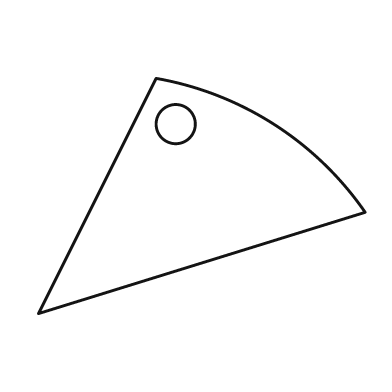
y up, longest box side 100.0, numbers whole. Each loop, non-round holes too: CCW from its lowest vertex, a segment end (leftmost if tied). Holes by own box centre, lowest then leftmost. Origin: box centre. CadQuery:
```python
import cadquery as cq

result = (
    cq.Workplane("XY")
    .moveTo(-50.0, -36.0)
    .lineTo(50.0, -5.0)
    .threePointArc((22.0, 22.0), (-14.0, 36.0))
    .close()
    .moveTo(-8.0, 22.0)
    .circle(6.0)
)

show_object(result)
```